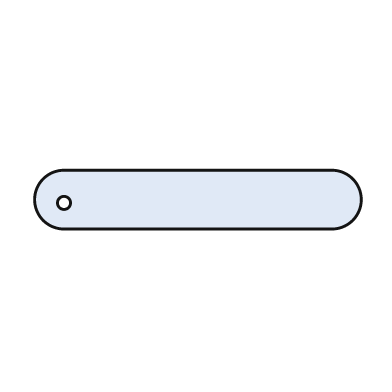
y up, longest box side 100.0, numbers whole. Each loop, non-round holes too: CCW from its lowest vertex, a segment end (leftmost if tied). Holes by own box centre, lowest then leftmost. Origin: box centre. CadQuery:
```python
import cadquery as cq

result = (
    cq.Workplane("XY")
    .moveTo(-41.0, -9.0)
    .lineTo(41.0, -9.0)
    .threePointArc((50.0, 0.0), (41.0, 9.0))
    .lineTo(-41.0, 9.0)
    .threePointArc((-50.0, 0.0), (-41.0, -9.0))
    .close()
    .moveTo(-41.0, -1.0)
    .circle(2.0)
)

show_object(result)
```